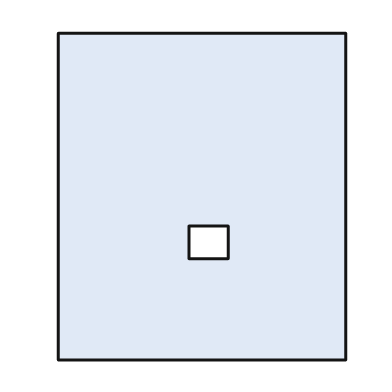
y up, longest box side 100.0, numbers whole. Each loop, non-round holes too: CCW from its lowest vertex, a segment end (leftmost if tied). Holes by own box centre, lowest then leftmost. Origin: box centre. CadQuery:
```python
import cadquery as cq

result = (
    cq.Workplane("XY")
    .moveTo(-44.0, -50.0)
    .lineTo(44.0, -50.0)
    .lineTo(44.0, 50.0)
    .lineTo(-44.0, 50.0)
    .close()
    .moveTo(-4.0, -19.0)
    .lineTo(8.0, -19.0)
    .lineTo(8.0, -9.0)
    .lineTo(-4.0, -9.0)
    .close()
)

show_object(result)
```